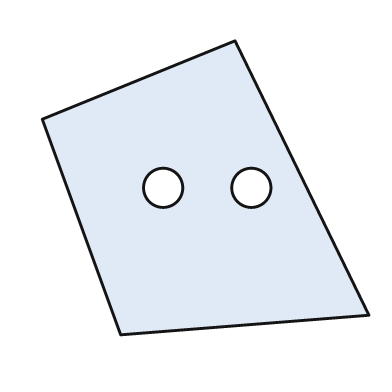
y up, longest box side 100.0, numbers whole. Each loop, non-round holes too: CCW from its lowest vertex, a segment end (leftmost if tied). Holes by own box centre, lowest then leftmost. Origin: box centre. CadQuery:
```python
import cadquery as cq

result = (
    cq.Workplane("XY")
    .moveTo(-26.0, -45.0)
    .lineTo(50.0, -39.0)
    .lineTo(9.0, 45.0)
    .lineTo(-50.0, 21.0)
    .close()
    .moveTo(-13.0, 0.0)
    .circle(6.0)
    .moveTo(14.0, 0.0)
    .circle(6.0)
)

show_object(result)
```